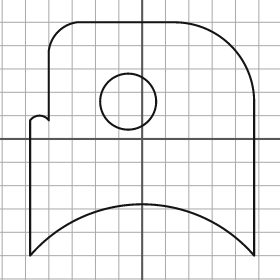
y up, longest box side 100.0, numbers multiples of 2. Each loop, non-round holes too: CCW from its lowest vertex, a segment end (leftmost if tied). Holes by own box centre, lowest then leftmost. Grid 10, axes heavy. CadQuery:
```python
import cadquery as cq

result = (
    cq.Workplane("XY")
    .moveTo(-48.0, -50.0)
    .threePointArc((0.0, -28.0), (48.0, -50.0))
    .lineTo(48.0, 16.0)
    .threePointArc((38.0, 40.0), (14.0, 50.0))
    .lineTo(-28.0, 50.0)
    .threePointArc((-36.0, 46.0), (-40.0, 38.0))
    .lineTo(-40.0, 8.0)
    .threePointArc((-44.0, 10.0), (-48.0, 8.0))
    .close()
    .moveTo(-6.0, 16.0)
    .circle(12.0)
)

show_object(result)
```